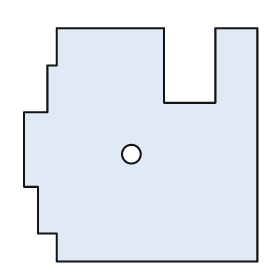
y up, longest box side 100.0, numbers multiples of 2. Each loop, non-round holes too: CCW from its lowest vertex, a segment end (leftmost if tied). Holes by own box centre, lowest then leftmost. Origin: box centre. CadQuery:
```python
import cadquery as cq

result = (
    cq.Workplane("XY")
    .moveTo(-36.0, -50.0)
    .lineTo(50.0, -50.0)
    .lineTo(50.0, 50.0)
    .lineTo(32.0, 50.0)
    .lineTo(32.0, 18.0)
    .lineTo(10.0, 18.0)
    .lineTo(10.0, 50.0)
    .lineTo(-36.0, 50.0)
    .lineTo(-36.0, 34.0)
    .lineTo(-40.0, 34.0)
    .lineTo(-40.0, 14.0)
    .lineTo(-50.0, 14.0)
    .lineTo(-50.0, -18.0)
    .lineTo(-44.0, -18.0)
    .lineTo(-44.0, -38.0)
    .lineTo(-36.0, -38.0)
    .close()
    .moveTo(-4.0, -4.0)
    .circle(4.0)
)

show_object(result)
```